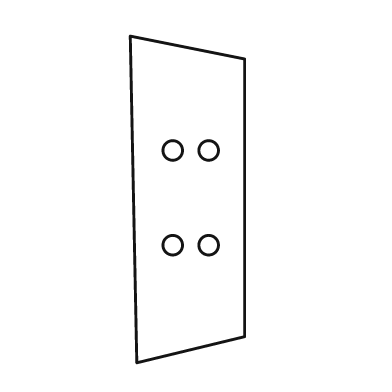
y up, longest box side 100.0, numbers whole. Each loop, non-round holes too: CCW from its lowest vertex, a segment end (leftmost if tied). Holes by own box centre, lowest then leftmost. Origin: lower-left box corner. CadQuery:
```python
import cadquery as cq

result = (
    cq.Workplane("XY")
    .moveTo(2.0, 0.0)
    .lineTo(35.0, 8.0)
    .lineTo(35.0, 93.0)
    .lineTo(0.0, 100.0)
    .close()
    .moveTo(13.0, 36.0)
    .circle(3.0)
    .moveTo(24.0, 36.0)
    .circle(3.0)
    .moveTo(13.0, 65.0)
    .circle(3.0)
    .moveTo(24.0, 65.0)
    .circle(3.0)
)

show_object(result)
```